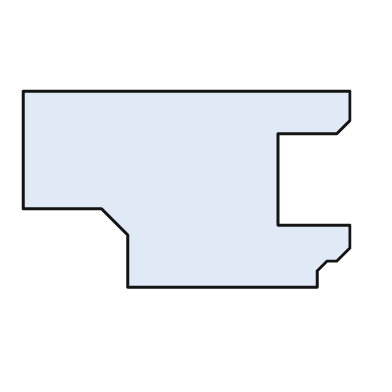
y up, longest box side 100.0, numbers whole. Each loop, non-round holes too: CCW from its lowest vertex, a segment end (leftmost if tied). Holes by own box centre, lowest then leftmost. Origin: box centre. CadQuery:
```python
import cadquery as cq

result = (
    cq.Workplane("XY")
    .moveTo(-18.0, -30.0)
    .lineTo(40.0, -30.0)
    .lineTo(40.0, -25.0)
    .lineTo(43.0, -22.0)
    .lineTo(46.0, -22.0)
    .lineTo(50.0, -18.0)
    .lineTo(50.0, -11.0)
    .lineTo(28.0, -11.0)
    .lineTo(28.0, 17.0)
    .lineTo(46.0, 17.0)
    .lineTo(50.0, 21.0)
    .lineTo(50.0, 30.0)
    .lineTo(-50.0, 30.0)
    .lineTo(-50.0, -6.0)
    .lineTo(-26.0, -6.0)
    .lineTo(-18.0, -14.0)
    .close()
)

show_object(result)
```